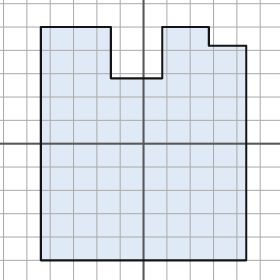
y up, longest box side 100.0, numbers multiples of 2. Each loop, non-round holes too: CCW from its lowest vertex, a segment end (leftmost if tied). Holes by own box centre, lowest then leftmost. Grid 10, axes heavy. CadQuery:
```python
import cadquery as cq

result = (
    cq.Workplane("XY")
    .moveTo(-44.0, -50.0)
    .lineTo(44.0, -50.0)
    .lineTo(44.0, 42.0)
    .lineTo(28.0, 42.0)
    .lineTo(28.0, 50.0)
    .lineTo(8.0, 50.0)
    .lineTo(8.0, 28.0)
    .lineTo(-14.0, 28.0)
    .lineTo(-14.0, 50.0)
    .lineTo(-44.0, 50.0)
    .close()
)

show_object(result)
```